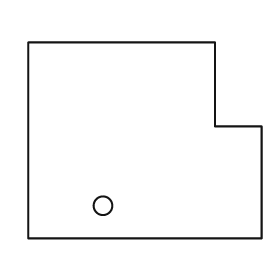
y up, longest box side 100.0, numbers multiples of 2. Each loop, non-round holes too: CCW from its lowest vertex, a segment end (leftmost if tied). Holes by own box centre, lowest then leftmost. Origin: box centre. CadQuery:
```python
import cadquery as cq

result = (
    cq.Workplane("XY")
    .moveTo(-50.0, -42.0)
    .lineTo(50.0, -42.0)
    .lineTo(50.0, 6.0)
    .lineTo(30.0, 6.0)
    .lineTo(30.0, 42.0)
    .lineTo(-50.0, 42.0)
    .close()
    .moveTo(-18.0, -28.0)
    .circle(4.0)
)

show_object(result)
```